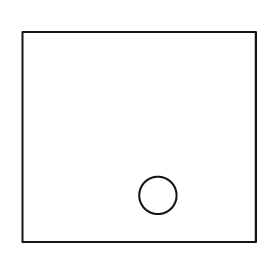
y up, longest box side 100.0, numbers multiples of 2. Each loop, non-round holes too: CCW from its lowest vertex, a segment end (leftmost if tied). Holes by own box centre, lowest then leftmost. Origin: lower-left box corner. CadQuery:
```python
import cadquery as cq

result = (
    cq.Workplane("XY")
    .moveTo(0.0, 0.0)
    .lineTo(100.0, 0.0)
    .lineTo(100.0, 90.0)
    .lineTo(0.0, 90.0)
    .close()
    .moveTo(58.0, 20.0)
    .circle(8.0)
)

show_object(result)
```